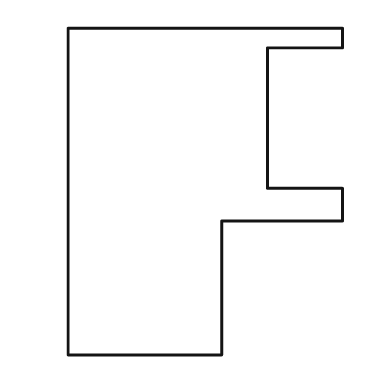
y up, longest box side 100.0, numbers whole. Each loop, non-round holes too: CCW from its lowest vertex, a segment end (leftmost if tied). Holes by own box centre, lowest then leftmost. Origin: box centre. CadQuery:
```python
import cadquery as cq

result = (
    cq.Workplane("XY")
    .moveTo(-42.0, -50.0)
    .lineTo(5.0, -50.0)
    .lineTo(5.0, -9.0)
    .lineTo(42.0, -9.0)
    .lineTo(42.0, 1.0)
    .lineTo(19.0, 1.0)
    .lineTo(19.0, 44.0)
    .lineTo(42.0, 44.0)
    .lineTo(42.0, 50.0)
    .lineTo(-42.0, 50.0)
    .close()
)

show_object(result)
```